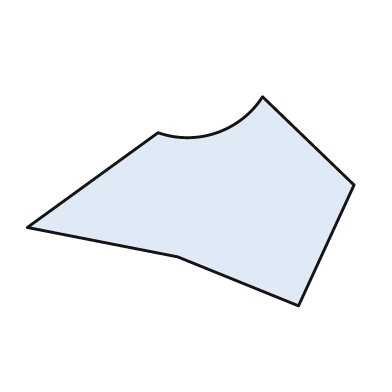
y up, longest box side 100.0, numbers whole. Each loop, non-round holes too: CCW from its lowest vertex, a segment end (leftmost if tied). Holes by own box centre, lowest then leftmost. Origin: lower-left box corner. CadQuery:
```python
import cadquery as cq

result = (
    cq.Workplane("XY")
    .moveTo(83.0, 0.0)
    .lineTo(100.0, 37.0)
    .lineTo(72.0, 64.0)
    .threePointArc((58.0, 53.0), (40.0, 53.0))
    .lineTo(0.0, 24.0)
    .lineTo(46.0, 15.0)
    .close()
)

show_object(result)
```